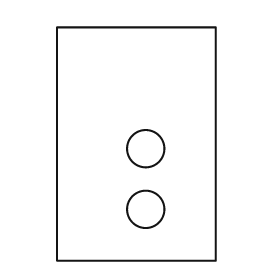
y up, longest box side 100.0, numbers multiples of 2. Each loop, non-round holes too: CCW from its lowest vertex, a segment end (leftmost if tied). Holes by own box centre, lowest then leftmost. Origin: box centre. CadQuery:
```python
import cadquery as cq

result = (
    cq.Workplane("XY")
    .moveTo(-34.0, -50.0)
    .lineTo(34.0, -50.0)
    .lineTo(34.0, 50.0)
    .lineTo(-34.0, 50.0)
    .close()
    .moveTo(4.0, -28.0)
    .circle(8.0)
    .moveTo(4.0, -2.0)
    .circle(8.0)
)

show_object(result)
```